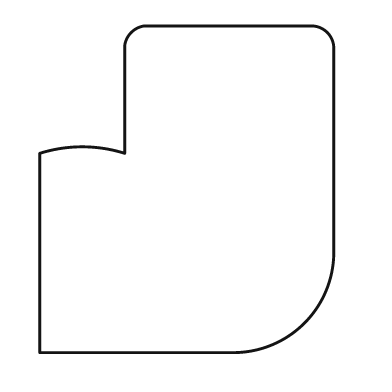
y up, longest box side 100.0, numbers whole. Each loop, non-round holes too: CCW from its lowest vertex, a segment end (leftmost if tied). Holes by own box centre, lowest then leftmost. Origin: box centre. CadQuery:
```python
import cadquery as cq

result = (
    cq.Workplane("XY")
    .moveTo(-45.0, -50.0)
    .lineTo(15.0, -50.0)
    .threePointArc((36.0, -41.0), (45.0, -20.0))
    .lineTo(45.0, 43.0)
    .threePointArc((43.0, 48.0), (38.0, 50.0))
    .lineTo(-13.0, 50.0)
    .threePointArc((-17.0, 48.0), (-19.0, 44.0))
    .lineTo(-19.0, 11.0)
    .threePointArc((-32.0, 13.0), (-45.0, 11.0))
    .close()
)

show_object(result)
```